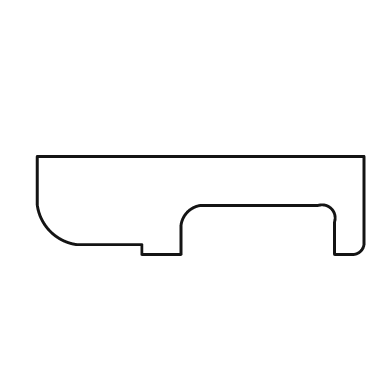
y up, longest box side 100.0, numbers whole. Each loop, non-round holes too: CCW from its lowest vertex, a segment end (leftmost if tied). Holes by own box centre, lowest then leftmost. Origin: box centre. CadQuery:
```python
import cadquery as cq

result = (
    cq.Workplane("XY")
    .moveTo(-18.0, -15.0)
    .lineTo(-6.0, -15.0)
    .lineTo(-6.0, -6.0)
    .threePointArc((-4.0, -2.0), (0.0, 0.0))
    .lineTo(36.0, 0.0)
    .threePointArc((40.0, -1.0), (41.0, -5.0))
    .lineTo(41.0, -15.0)
    .lineTo(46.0, -15.0)
    .threePointArc((49.0, -14.0), (50.0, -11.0))
    .lineTo(50.0, 15.0)
    .lineTo(-50.0, 15.0)
    .lineTo(-50.0, 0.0)
    .threePointArc((-46.0, -8.0), (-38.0, -12.0))
    .lineTo(-18.0, -12.0)
    .close()
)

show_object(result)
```